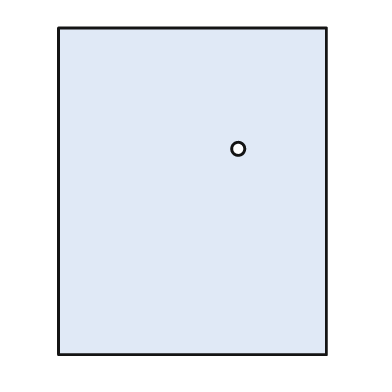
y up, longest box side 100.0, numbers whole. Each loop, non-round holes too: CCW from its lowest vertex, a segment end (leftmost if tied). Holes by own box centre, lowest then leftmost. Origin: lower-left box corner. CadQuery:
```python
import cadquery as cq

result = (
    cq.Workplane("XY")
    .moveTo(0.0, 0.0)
    .lineTo(82.0, 0.0)
    .lineTo(82.0, 100.0)
    .lineTo(0.0, 100.0)
    .close()
    .moveTo(55.0, 63.0)
    .circle(2.0)
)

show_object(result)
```